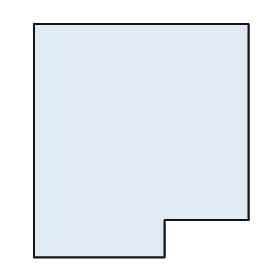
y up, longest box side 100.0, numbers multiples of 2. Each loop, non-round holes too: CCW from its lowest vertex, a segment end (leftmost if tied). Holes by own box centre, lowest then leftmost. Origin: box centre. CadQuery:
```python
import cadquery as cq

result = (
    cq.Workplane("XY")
    .moveTo(-46.0, -50.0)
    .lineTo(10.0, -50.0)
    .lineTo(10.0, -34.0)
    .lineTo(46.0, -34.0)
    .lineTo(46.0, 50.0)
    .lineTo(-46.0, 50.0)
    .close()
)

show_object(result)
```